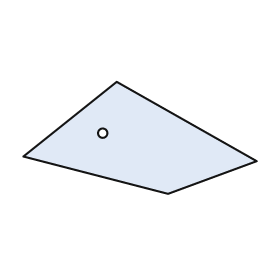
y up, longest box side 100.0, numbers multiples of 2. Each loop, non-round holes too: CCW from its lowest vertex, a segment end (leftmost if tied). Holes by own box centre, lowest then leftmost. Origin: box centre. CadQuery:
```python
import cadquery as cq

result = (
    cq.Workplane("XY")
    .moveTo(12.0, -24.0)
    .lineTo(50.0, -10.0)
    .lineTo(-10.0, 24.0)
    .lineTo(-50.0, -8.0)
    .close()
    .moveTo(-16.0, 2.0)
    .circle(2.0)
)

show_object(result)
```